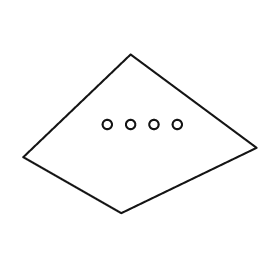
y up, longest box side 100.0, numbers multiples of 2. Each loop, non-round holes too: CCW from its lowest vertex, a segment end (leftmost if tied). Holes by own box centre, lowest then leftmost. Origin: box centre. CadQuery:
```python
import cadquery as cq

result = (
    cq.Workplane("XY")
    .moveTo(-8.0, -34.0)
    .lineTo(50.0, -6.0)
    .lineTo(-4.0, 34.0)
    .lineTo(-50.0, -10.0)
    .close()
    .moveTo(-14.0, 4.0)
    .circle(2.0)
    .moveTo(-4.0, 4.0)
    .circle(2.0)
    .moveTo(6.0, 4.0)
    .circle(2.0)
    .moveTo(16.0, 4.0)
    .circle(2.0)
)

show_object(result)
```